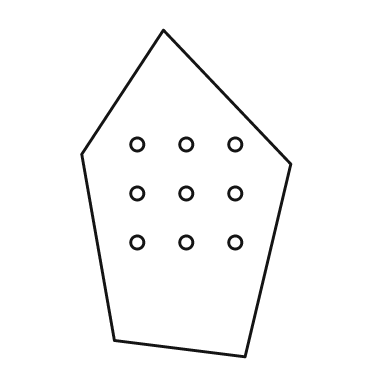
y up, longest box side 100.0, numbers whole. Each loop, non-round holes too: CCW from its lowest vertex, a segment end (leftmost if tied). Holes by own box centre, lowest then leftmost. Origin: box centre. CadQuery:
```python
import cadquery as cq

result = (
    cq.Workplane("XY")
    .moveTo(18.0, -50.0)
    .lineTo(32.0, 9.0)
    .lineTo(-7.0, 50.0)
    .lineTo(-32.0, 12.0)
    .lineTo(-22.0, -45.0)
    .close()
    .moveTo(-15.0, -15.0)
    .circle(2.0)
    .moveTo(0.0, -15.0)
    .circle(2.0)
    .moveTo(15.0, -15.0)
    .circle(2.0)
    .moveTo(-15.0, 0.0)
    .circle(2.0)
    .moveTo(0.0, 0.0)
    .circle(2.0)
    .moveTo(15.0, 0.0)
    .circle(2.0)
    .moveTo(-15.0, 15.0)
    .circle(2.0)
    .moveTo(0.0, 15.0)
    .circle(2.0)
    .moveTo(15.0, 15.0)
    .circle(2.0)
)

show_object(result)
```